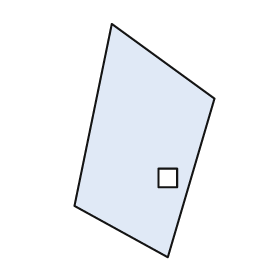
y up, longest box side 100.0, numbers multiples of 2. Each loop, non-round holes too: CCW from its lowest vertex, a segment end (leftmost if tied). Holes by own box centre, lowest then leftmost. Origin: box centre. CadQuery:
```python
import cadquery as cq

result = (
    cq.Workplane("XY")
    .moveTo(10.0, -50.0)
    .lineTo(30.0, 18.0)
    .lineTo(-14.0, 50.0)
    .lineTo(-30.0, -28.0)
    .close()
    .moveTo(6.0, -20.0)
    .lineTo(14.0, -20.0)
    .lineTo(14.0, -12.0)
    .lineTo(6.0, -12.0)
    .close()
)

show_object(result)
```